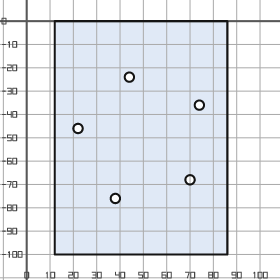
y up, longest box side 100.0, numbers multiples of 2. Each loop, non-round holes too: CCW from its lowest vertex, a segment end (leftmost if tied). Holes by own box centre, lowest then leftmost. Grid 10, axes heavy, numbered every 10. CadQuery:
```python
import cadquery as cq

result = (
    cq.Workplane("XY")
    .moveTo(12.0, -100.0)
    .lineTo(86.0, -100.0)
    .lineTo(86.0, 0.0)
    .lineTo(12.0, 0.0)
    .close()
    .moveTo(38.0, -76.0)
    .circle(2.0)
    .moveTo(70.0, -68.0)
    .circle(2.0)
    .moveTo(22.0, -46.0)
    .circle(2.0)
    .moveTo(74.0, -36.0)
    .circle(2.0)
    .moveTo(44.0, -24.0)
    .circle(2.0)
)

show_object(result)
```